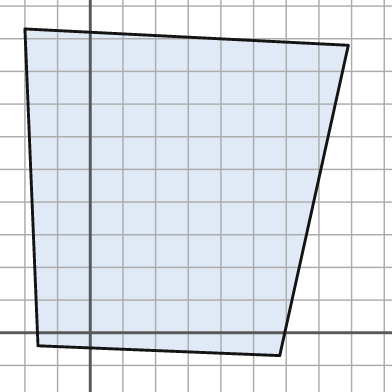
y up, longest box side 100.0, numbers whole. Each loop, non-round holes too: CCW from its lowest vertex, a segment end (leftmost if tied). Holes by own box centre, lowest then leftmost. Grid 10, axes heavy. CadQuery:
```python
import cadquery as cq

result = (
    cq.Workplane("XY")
    .moveTo(58.0, -7.0)
    .lineTo(79.0, 88.0)
    .lineTo(-20.0, 93.0)
    .lineTo(-16.0, -4.0)
    .close()
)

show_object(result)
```